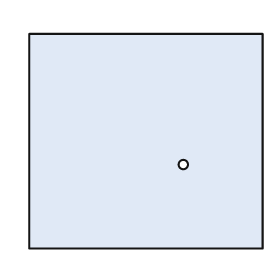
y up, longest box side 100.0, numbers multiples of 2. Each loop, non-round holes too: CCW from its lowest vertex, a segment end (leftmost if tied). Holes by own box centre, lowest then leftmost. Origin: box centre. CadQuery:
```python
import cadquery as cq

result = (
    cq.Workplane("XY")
    .moveTo(-50.0, -46.0)
    .lineTo(50.0, -46.0)
    .lineTo(50.0, 46.0)
    .lineTo(-50.0, 46.0)
    .close()
    .moveTo(16.0, -10.0)
    .circle(2.0)
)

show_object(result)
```